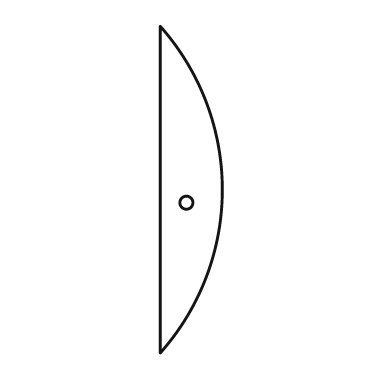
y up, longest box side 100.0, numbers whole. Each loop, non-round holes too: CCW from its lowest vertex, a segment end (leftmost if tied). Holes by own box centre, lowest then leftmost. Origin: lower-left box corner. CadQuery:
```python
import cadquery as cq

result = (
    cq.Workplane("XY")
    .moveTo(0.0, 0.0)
    .threePointArc((19.0, 50.0), (0.0, 100.0))
    .close()
    .moveTo(8.0, 46.0)
    .circle(2.0)
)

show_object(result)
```